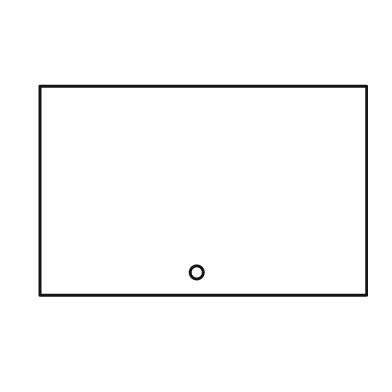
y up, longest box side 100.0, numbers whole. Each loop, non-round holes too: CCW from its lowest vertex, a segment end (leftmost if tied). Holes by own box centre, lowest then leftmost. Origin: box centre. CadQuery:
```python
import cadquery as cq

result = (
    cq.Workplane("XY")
    .moveTo(-50.0, -32.0)
    .lineTo(50.0, -32.0)
    .lineTo(50.0, 32.0)
    .lineTo(-50.0, 32.0)
    .close()
    .moveTo(-2.0, -25.0)
    .circle(2.0)
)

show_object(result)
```